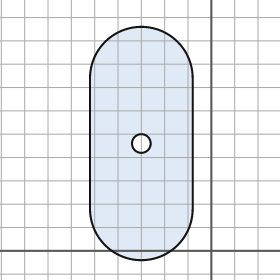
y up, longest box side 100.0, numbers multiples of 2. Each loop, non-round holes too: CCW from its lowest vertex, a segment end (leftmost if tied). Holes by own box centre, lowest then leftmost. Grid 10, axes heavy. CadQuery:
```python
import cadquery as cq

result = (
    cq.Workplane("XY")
    .moveTo(-52.0, 18.0)
    .threePointArc((-30.0, -4.0), (-8.0, 18.0))
    .lineTo(-8.0, 74.0)
    .threePointArc((-30.0, 96.0), (-52.0, 74.0))
    .close()
    .moveTo(-30.0, 46.0)
    .circle(4.0)
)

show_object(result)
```